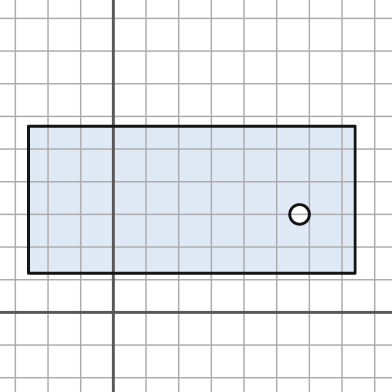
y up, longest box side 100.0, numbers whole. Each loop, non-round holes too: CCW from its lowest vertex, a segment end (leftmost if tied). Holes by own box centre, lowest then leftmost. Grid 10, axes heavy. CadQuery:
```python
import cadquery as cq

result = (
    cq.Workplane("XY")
    .moveTo(-26.0, 12.0)
    .lineTo(74.0, 12.0)
    .lineTo(74.0, 57.0)
    .lineTo(-26.0, 57.0)
    .close()
    .moveTo(57.0, 30.0)
    .circle(3.0)
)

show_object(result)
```